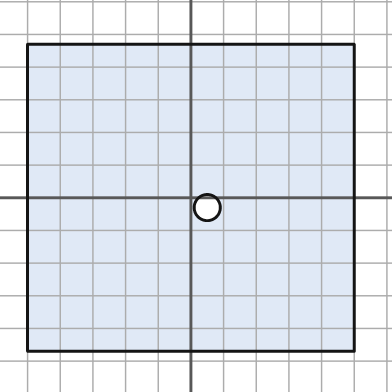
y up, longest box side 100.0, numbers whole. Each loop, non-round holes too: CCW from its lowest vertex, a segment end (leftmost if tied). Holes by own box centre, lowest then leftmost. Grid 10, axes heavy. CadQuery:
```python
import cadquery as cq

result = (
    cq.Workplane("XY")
    .moveTo(-50.0, -47.0)
    .lineTo(50.0, -47.0)
    .lineTo(50.0, 47.0)
    .lineTo(-50.0, 47.0)
    .close()
    .moveTo(5.0, -3.0)
    .circle(4.0)
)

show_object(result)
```